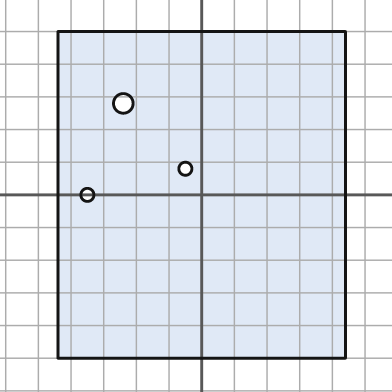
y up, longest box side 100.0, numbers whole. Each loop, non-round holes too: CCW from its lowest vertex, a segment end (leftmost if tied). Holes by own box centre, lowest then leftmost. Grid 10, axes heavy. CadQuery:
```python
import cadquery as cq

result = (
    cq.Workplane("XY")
    .moveTo(-44.0, -50.0)
    .lineTo(44.0, -50.0)
    .lineTo(44.0, 50.0)
    .lineTo(-44.0, 50.0)
    .close()
    .moveTo(-35.0, 0.0)
    .circle(2.0)
    .moveTo(-5.0, 8.0)
    .circle(2.0)
    .moveTo(-24.0, 28.0)
    .circle(3.0)
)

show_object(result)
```